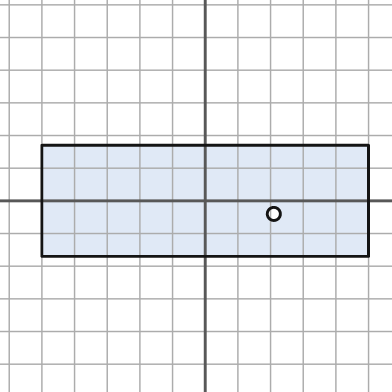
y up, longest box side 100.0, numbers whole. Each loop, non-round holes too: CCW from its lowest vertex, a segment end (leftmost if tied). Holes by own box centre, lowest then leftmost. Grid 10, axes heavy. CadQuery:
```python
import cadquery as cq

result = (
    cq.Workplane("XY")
    .moveTo(-50.0, -17.0)
    .lineTo(50.0, -17.0)
    .lineTo(50.0, 17.0)
    .lineTo(-50.0, 17.0)
    .close()
    .moveTo(21.0, -4.0)
    .circle(2.0)
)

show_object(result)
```